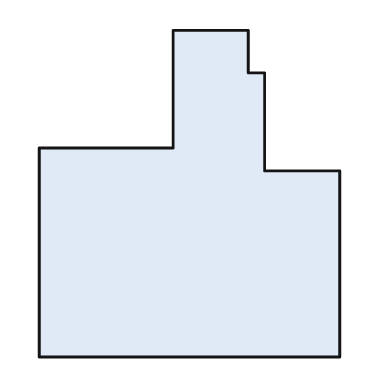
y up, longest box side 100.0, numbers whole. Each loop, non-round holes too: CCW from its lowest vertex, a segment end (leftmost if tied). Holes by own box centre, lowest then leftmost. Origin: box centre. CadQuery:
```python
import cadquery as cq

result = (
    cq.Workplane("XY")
    .moveTo(-46.0, -50.0)
    .lineTo(46.0, -50.0)
    .lineTo(46.0, 7.0)
    .lineTo(23.0, 7.0)
    .lineTo(23.0, 37.0)
    .lineTo(18.0, 37.0)
    .lineTo(18.0, 50.0)
    .lineTo(-5.0, 50.0)
    .lineTo(-5.0, 14.0)
    .lineTo(-46.0, 14.0)
    .close()
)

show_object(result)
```